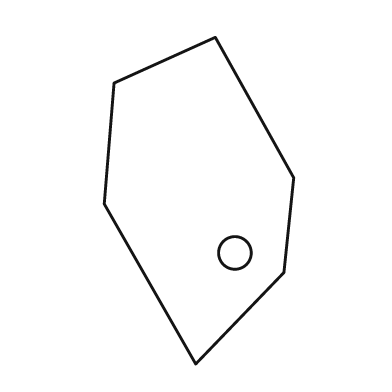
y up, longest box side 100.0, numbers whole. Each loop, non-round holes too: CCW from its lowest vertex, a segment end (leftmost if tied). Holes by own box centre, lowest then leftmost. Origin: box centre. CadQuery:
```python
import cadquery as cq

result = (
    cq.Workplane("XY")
    .moveTo(-1.0, -50.0)
    .lineTo(26.0, -22.0)
    .lineTo(29.0, 7.0)
    .lineTo(5.0, 50.0)
    .lineTo(-26.0, 36.0)
    .lineTo(-29.0, -1.0)
    .close()
    .moveTo(11.0, -16.0)
    .circle(5.0)
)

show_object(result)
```